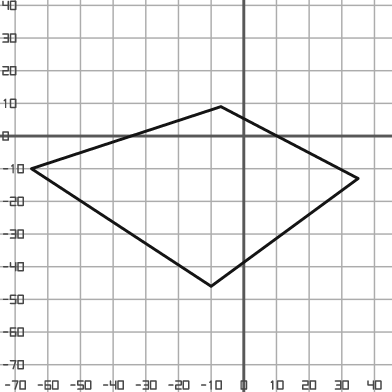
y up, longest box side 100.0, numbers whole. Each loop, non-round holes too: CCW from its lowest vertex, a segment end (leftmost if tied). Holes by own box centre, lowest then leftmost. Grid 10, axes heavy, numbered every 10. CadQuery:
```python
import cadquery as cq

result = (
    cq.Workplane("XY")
    .moveTo(-10.0, -46.0)
    .lineTo(35.0, -13.0)
    .lineTo(-7.0, 9.0)
    .lineTo(-65.0, -10.0)
    .close()
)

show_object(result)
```